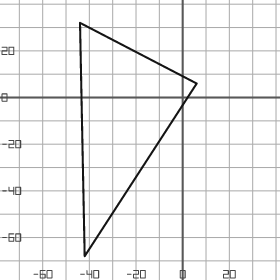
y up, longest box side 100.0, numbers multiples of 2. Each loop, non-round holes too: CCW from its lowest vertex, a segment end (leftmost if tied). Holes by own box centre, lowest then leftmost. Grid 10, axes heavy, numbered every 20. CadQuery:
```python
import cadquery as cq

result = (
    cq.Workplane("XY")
    .moveTo(-42.0, -68.0)
    .lineTo(6.0, 6.0)
    .lineTo(-44.0, 32.0)
    .close()
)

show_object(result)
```